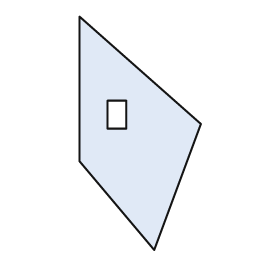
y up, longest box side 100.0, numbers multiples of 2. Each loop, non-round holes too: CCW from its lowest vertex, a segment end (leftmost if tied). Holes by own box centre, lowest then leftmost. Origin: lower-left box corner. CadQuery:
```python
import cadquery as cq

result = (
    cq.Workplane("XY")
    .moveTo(32.0, 0.0)
    .lineTo(52.0, 54.0)
    .lineTo(0.0, 100.0)
    .lineTo(0.0, 38.0)
    .close()
    .moveTo(12.0, 52.0)
    .lineTo(20.0, 52.0)
    .lineTo(20.0, 64.0)
    .lineTo(12.0, 64.0)
    .close()
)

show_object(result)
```